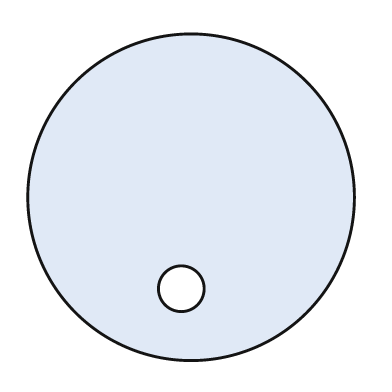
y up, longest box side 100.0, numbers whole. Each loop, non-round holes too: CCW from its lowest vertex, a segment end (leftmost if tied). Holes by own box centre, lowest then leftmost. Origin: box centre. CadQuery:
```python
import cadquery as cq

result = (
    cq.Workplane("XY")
    .moveTo(0.0, 0.0)
    .circle(50.0)
    .moveTo(-3.0, -28.0)
    .circle(7.0)
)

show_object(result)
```